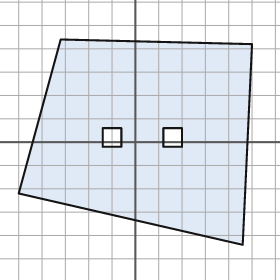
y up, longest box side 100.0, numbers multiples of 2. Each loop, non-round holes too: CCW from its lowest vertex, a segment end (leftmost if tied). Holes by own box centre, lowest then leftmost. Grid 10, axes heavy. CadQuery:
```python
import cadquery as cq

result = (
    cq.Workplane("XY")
    .moveTo(46.0, -44.0)
    .lineTo(50.0, 42.0)
    .lineTo(-32.0, 44.0)
    .lineTo(-50.0, -22.0)
    .close()
    .moveTo(-14.0, -2.0)
    .lineTo(-6.0, -2.0)
    .lineTo(-6.0, 6.0)
    .lineTo(-14.0, 6.0)
    .close()
    .moveTo(12.0, -2.0)
    .lineTo(20.0, -2.0)
    .lineTo(20.0, 6.0)
    .lineTo(12.0, 6.0)
    .close()
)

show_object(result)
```